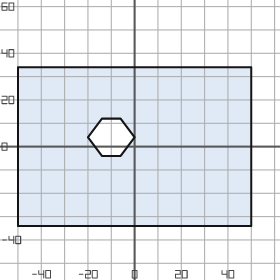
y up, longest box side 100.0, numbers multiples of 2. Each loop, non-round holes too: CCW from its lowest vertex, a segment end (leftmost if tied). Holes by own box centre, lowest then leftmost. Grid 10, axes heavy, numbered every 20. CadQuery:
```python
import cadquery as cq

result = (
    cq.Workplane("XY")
    .moveTo(-50.0, -34.0)
    .lineTo(50.0, -34.0)
    .lineTo(50.0, 34.0)
    .lineTo(-50.0, 34.0)
    .close()
    .moveTo(-14.0, -4.0)
    .lineTo(-6.0, -4.0)
    .lineTo(0.0, 4.0)
    .lineTo(-6.0, 12.0)
    .lineTo(-14.0, 12.0)
    .lineTo(-20.0, 4.0)
    .close()
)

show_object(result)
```